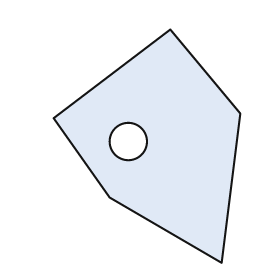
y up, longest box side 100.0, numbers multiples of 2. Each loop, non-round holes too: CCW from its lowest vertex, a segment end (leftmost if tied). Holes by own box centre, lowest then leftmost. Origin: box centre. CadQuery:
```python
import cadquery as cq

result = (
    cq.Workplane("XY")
    .moveTo(32.0, -50.0)
    .lineTo(40.0, 14.0)
    .lineTo(10.0, 50.0)
    .lineTo(-40.0, 12.0)
    .lineTo(-16.0, -22.0)
    .close()
    .moveTo(-8.0, 2.0)
    .circle(8.0)
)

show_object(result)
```